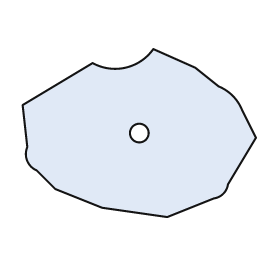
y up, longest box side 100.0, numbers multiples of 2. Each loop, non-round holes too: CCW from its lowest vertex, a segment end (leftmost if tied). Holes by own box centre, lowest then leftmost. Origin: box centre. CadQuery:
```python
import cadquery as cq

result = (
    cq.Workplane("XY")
    .moveTo(12.0, -36.0)
    .lineTo(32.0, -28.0)
    .threePointArc((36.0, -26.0), (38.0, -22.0))
    .lineTo(50.0, -2.0)
    .lineTo(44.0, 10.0)
    .threePointArc((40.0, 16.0), (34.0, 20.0))
    .lineTo(24.0, 28.0)
    .lineTo(6.0, 36.0)
    .threePointArc((-6.0, 28.0), (-20.0, 30.0))
    .lineTo(-50.0, 12.0)
    .lineTo(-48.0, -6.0)
    .threePointArc((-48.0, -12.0), (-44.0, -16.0))
    .lineTo(-36.0, -24.0)
    .lineTo(-16.0, -32.0)
    .close()
    .moveTo(0.0, 0.0)
    .circle(4.0)
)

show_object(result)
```